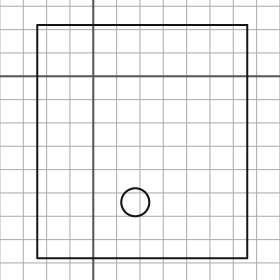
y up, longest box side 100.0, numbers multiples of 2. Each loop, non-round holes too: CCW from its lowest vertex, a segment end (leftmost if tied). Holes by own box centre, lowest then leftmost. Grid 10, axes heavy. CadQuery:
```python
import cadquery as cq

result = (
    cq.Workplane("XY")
    .moveTo(-24.0, -78.0)
    .lineTo(66.0, -78.0)
    .lineTo(66.0, 22.0)
    .lineTo(-24.0, 22.0)
    .close()
    .moveTo(18.0, -54.0)
    .circle(6.0)
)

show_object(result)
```